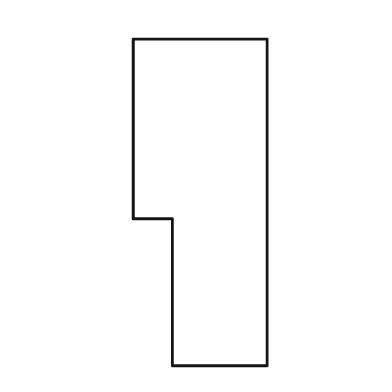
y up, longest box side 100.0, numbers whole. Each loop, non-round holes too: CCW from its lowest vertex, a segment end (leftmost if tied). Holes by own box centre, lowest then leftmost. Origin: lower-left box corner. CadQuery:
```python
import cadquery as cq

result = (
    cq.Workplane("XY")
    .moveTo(12.0, 0.0)
    .lineTo(41.0, 0.0)
    .lineTo(41.0, 100.0)
    .lineTo(0.0, 100.0)
    .lineTo(0.0, 45.0)
    .lineTo(12.0, 45.0)
    .close()
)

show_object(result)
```